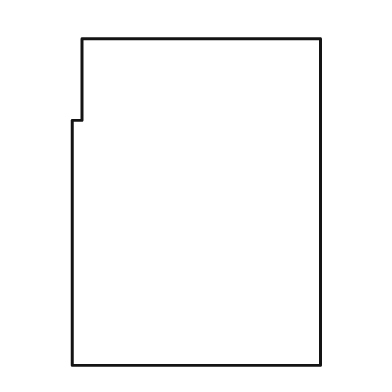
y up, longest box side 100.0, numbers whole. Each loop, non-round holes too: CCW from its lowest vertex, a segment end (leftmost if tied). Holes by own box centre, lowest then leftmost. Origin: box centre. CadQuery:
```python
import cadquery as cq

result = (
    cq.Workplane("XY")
    .moveTo(-38.0, -50.0)
    .lineTo(38.0, -50.0)
    .lineTo(38.0, 50.0)
    .lineTo(-35.0, 50.0)
    .lineTo(-35.0, 25.0)
    .lineTo(-38.0, 25.0)
    .close()
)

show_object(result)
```